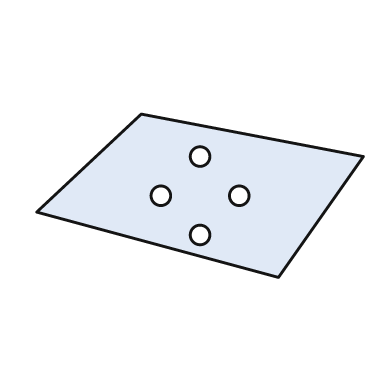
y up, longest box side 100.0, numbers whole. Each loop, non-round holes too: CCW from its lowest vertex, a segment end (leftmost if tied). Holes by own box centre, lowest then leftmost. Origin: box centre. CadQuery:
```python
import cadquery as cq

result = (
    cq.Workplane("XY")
    .moveTo(24.0, -25.0)
    .lineTo(50.0, 12.0)
    .lineTo(-18.0, 25.0)
    .lineTo(-50.0, -5.0)
    .close()
    .moveTo(0.0, -12.0)
    .circle(3.0)
    .moveTo(-12.0, 0.0)
    .circle(3.0)
    .moveTo(12.0, 0.0)
    .circle(3.0)
    .moveTo(0.0, 12.0)
    .circle(3.0)
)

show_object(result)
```